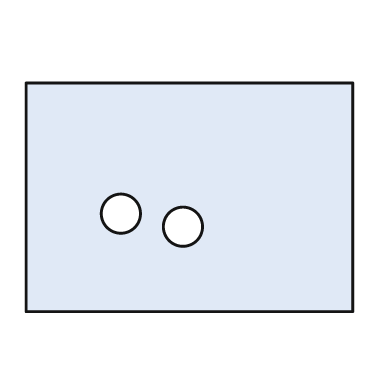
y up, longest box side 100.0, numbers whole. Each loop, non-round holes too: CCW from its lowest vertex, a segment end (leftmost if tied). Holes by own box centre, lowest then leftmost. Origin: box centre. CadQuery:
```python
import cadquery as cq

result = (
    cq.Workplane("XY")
    .moveTo(-50.0, -35.0)
    .lineTo(50.0, -35.0)
    .lineTo(50.0, 35.0)
    .lineTo(-50.0, 35.0)
    .close()
    .moveTo(-2.0, -9.0)
    .circle(6.0)
    .moveTo(-21.0, -5.0)
    .circle(6.0)
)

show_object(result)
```